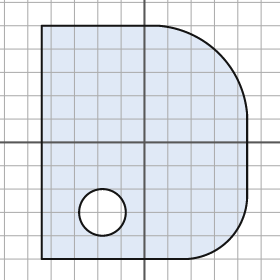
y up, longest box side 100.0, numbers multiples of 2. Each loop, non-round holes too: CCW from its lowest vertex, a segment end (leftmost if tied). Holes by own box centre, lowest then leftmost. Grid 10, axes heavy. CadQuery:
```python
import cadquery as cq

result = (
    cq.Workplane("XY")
    .moveTo(-44.0, -50.0)
    .lineTo(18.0, -50.0)
    .threePointArc((36.0, -42.0), (44.0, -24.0))
    .lineTo(44.0, 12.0)
    .threePointArc((32.0, 38.0), (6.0, 50.0))
    .lineTo(-44.0, 50.0)
    .close()
    .moveTo(-18.0, -30.0)
    .circle(10.0)
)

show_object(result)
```